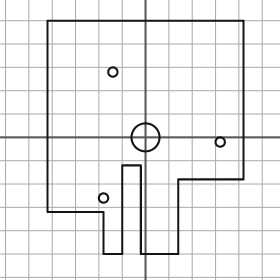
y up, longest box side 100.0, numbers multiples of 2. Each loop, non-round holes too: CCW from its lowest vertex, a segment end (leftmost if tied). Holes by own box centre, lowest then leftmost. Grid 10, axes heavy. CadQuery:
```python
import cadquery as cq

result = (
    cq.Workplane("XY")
    .moveTo(-18.0, -50.0)
    .lineTo(-10.0, -50.0)
    .lineTo(-10.0, -12.0)
    .lineTo(-2.0, -12.0)
    .lineTo(-2.0, -50.0)
    .lineTo(14.0, -50.0)
    .lineTo(14.0, -18.0)
    .lineTo(42.0, -18.0)
    .lineTo(42.0, 50.0)
    .lineTo(-42.0, 50.0)
    .lineTo(-42.0, -32.0)
    .lineTo(-18.0, -32.0)
    .close()
    .moveTo(-18.0, -26.0)
    .circle(2.0)
    .moveTo(32.0, -2.0)
    .circle(2.0)
    .moveTo(0.0, 0.0)
    .circle(6.0)
    .moveTo(-14.0, 28.0)
    .circle(2.0)
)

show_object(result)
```